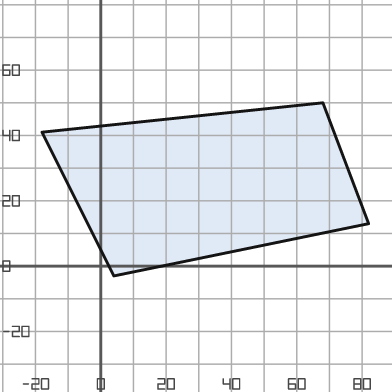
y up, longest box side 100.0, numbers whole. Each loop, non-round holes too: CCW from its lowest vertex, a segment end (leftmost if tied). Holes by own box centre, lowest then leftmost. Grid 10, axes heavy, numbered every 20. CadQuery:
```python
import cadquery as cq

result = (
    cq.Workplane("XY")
    .moveTo(4.0, -3.0)
    .lineTo(82.0, 13.0)
    .lineTo(68.0, 50.0)
    .lineTo(-18.0, 41.0)
    .close()
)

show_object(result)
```